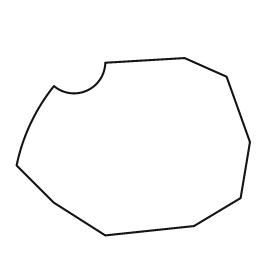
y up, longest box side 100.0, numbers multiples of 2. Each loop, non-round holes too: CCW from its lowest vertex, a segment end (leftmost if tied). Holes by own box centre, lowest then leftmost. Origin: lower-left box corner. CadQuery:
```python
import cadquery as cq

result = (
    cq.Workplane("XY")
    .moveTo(38.0, 0.0)
    .lineTo(76.0, 4.0)
    .lineTo(96.0, 16.0)
    .lineTo(100.0, 40.0)
    .lineTo(90.0, 68.0)
    .lineTo(72.0, 76.0)
    .lineTo(38.0, 74.0)
    .threePointArc((30.0, 62.0), (16.0, 64.0))
    .threePointArc((6.0, 48.0), (0.0, 30.0))
    .lineTo(16.0, 14.0)
    .close()
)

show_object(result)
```